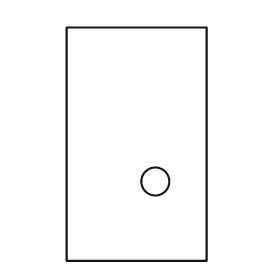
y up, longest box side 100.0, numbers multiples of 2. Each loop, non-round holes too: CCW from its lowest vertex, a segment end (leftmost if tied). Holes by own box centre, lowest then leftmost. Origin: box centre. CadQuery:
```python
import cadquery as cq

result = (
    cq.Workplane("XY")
    .moveTo(-30.0, -50.0)
    .lineTo(30.0, -50.0)
    .lineTo(30.0, 50.0)
    .lineTo(-30.0, 50.0)
    .close()
    .moveTo(8.0, -16.0)
    .circle(6.0)
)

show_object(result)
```